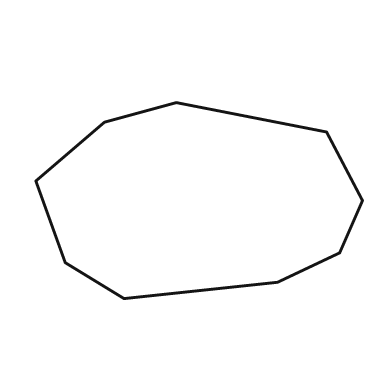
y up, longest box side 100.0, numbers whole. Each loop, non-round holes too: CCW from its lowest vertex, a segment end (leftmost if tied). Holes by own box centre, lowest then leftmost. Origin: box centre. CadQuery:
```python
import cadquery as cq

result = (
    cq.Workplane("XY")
    .moveTo(-23.0, -30.0)
    .lineTo(24.0, -25.0)
    .lineTo(43.0, -16.0)
    .lineTo(50.0, 0.0)
    .lineTo(39.0, 21.0)
    .lineTo(-7.0, 30.0)
    .lineTo(-29.0, 24.0)
    .lineTo(-50.0, 6.0)
    .lineTo(-41.0, -19.0)
    .close()
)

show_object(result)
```